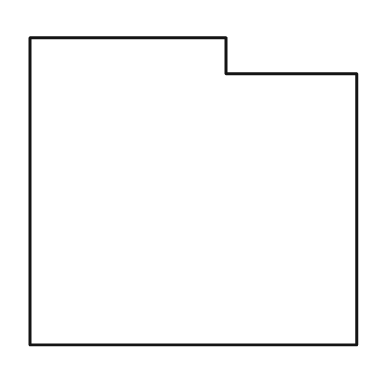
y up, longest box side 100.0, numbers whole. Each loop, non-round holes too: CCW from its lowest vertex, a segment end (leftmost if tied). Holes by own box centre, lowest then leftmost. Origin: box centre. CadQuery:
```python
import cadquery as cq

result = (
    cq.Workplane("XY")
    .moveTo(-50.0, -47.0)
    .lineTo(50.0, -47.0)
    .lineTo(50.0, 36.0)
    .lineTo(10.0, 36.0)
    .lineTo(10.0, 47.0)
    .lineTo(-50.0, 47.0)
    .close()
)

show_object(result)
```